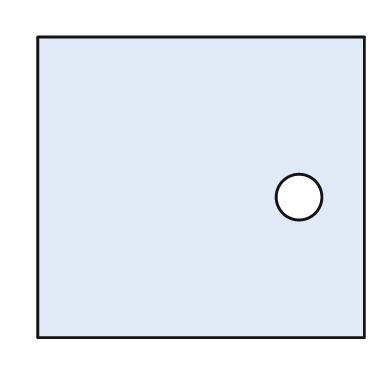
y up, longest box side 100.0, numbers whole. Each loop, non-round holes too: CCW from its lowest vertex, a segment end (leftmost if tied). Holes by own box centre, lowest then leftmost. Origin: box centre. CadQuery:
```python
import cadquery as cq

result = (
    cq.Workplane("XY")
    .moveTo(-50.0, -46.0)
    .lineTo(50.0, -46.0)
    .lineTo(50.0, 46.0)
    .lineTo(-50.0, 46.0)
    .close()
    .moveTo(30.0, -3.0)
    .circle(7.0)
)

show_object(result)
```